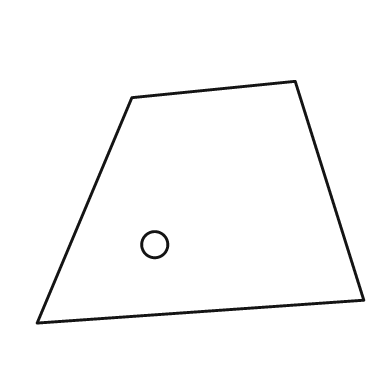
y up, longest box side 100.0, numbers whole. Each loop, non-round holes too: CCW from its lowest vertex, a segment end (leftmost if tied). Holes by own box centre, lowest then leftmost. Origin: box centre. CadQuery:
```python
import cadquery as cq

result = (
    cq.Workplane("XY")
    .moveTo(-50.0, -37.0)
    .lineTo(50.0, -30.0)
    .lineTo(29.0, 37.0)
    .lineTo(-21.0, 32.0)
    .close()
    .moveTo(-14.0, -13.0)
    .circle(4.0)
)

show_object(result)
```